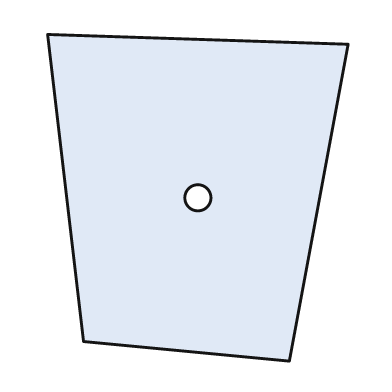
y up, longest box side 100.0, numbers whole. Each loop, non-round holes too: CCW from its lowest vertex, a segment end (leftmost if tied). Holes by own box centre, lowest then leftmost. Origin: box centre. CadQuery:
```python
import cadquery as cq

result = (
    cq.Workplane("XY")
    .moveTo(28.0, -50.0)
    .lineTo(46.0, 47.0)
    .lineTo(-46.0, 50.0)
    .lineTo(-35.0, -44.0)
    .close()
    .moveTo(0.0, 0.0)
    .circle(4.0)
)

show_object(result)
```